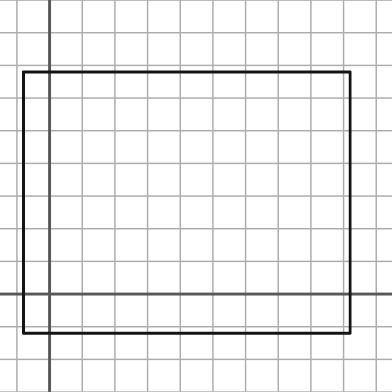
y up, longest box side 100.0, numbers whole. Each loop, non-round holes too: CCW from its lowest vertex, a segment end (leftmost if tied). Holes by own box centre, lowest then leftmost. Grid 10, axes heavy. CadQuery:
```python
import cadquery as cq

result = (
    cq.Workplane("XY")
    .moveTo(-8.0, -12.0)
    .lineTo(92.0, -12.0)
    .lineTo(92.0, 68.0)
    .lineTo(-8.0, 68.0)
    .close()
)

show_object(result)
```